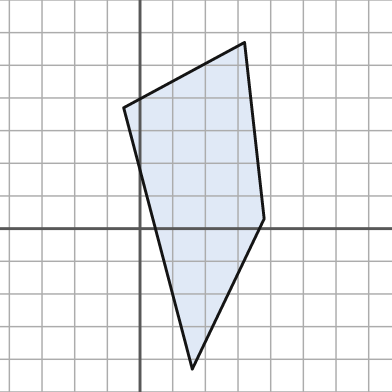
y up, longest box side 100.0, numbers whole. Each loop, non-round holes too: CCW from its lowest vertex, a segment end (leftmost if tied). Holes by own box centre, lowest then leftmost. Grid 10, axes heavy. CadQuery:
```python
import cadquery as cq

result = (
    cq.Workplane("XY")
    .moveTo(16.0, -43.0)
    .lineTo(38.0, 3.0)
    .lineTo(32.0, 57.0)
    .lineTo(-5.0, 37.0)
    .close()
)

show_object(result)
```